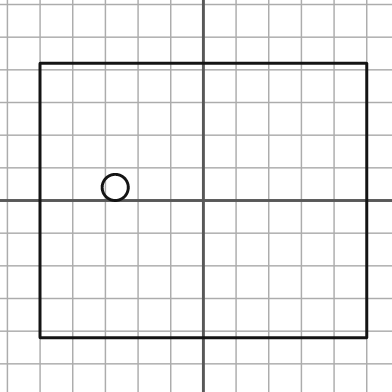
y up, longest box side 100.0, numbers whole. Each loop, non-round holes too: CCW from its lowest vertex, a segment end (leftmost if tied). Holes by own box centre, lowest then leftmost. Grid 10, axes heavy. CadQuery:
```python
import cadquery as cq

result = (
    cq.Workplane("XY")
    .moveTo(-50.0, -42.0)
    .lineTo(50.0, -42.0)
    .lineTo(50.0, 42.0)
    .lineTo(-50.0, 42.0)
    .close()
    .moveTo(-27.0, 4.0)
    .circle(4.0)
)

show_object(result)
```